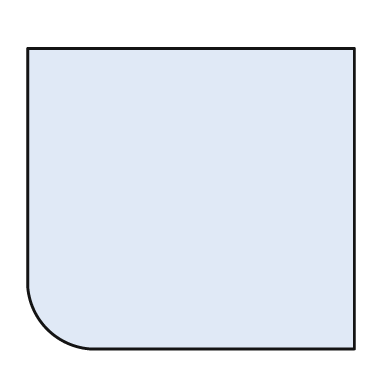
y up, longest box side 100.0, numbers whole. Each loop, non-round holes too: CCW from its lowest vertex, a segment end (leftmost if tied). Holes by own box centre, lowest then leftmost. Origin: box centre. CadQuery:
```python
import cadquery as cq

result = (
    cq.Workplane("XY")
    .moveTo(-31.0, -46.0)
    .lineTo(50.0, -46.0)
    .lineTo(50.0, 46.0)
    .lineTo(-50.0, 46.0)
    .lineTo(-50.0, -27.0)
    .threePointArc((-44.0, -40.0), (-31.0, -46.0))
    .close()
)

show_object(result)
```